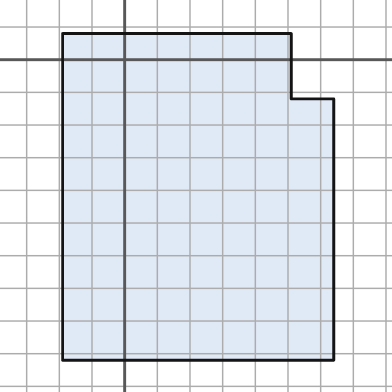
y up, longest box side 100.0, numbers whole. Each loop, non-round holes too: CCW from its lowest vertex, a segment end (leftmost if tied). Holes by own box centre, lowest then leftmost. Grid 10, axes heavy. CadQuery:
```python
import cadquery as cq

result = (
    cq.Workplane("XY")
    .moveTo(-19.0, -92.0)
    .lineTo(64.0, -92.0)
    .lineTo(64.0, -12.0)
    .lineTo(51.0, -12.0)
    .lineTo(51.0, 8.0)
    .lineTo(-19.0, 8.0)
    .close()
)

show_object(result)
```